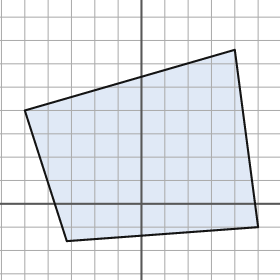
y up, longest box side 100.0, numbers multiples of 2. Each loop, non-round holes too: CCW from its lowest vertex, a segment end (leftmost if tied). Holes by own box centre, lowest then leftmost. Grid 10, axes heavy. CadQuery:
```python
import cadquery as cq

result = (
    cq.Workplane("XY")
    .moveTo(-32.0, -16.0)
    .lineTo(50.0, -10.0)
    .lineTo(40.0, 66.0)
    .lineTo(-50.0, 40.0)
    .close()
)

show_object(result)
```